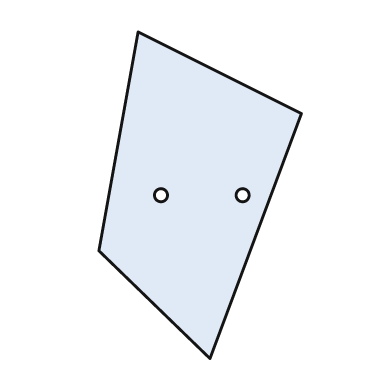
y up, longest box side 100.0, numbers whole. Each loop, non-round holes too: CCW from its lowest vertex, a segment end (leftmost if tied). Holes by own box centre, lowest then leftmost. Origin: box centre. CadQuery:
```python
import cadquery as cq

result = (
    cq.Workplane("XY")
    .moveTo(3.0, -50.0)
    .lineTo(31.0, 25.0)
    .lineTo(-19.0, 50.0)
    .lineTo(-31.0, -17.0)
    .close()
    .moveTo(-12.0, 0.0)
    .circle(2.0)
    .moveTo(13.0, 0.0)
    .circle(2.0)
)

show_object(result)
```